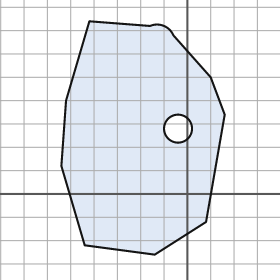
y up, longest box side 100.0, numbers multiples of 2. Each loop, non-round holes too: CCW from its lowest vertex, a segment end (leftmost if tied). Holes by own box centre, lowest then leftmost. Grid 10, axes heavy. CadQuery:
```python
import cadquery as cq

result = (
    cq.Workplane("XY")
    .moveTo(-14.0, -26.0)
    .lineTo(8.0, -12.0)
    .lineTo(16.0, 34.0)
    .lineTo(10.0, 50.0)
    .lineTo(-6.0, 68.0)
    .threePointArc((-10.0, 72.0), (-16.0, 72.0))
    .lineTo(-42.0, 74.0)
    .lineTo(-52.0, 40.0)
    .lineTo(-54.0, 12.0)
    .lineTo(-44.0, -22.0)
    .close()
    .moveTo(-4.0, 28.0)
    .circle(6.0)
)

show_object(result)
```